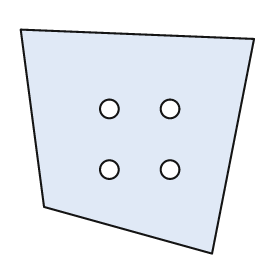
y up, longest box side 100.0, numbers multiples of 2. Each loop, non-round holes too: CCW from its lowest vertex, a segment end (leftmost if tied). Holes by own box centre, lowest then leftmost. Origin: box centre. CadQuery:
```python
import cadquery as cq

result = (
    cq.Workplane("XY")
    .moveTo(32.0, -48.0)
    .lineTo(50.0, 44.0)
    .lineTo(-50.0, 48.0)
    .lineTo(-40.0, -28.0)
    .close()
    .moveTo(-12.0, -12.0)
    .circle(4.0)
    .moveTo(14.0, -12.0)
    .circle(4.0)
    .moveTo(-12.0, 14.0)
    .circle(4.0)
    .moveTo(14.0, 14.0)
    .circle(4.0)
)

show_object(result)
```